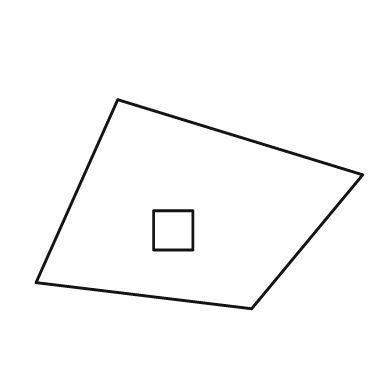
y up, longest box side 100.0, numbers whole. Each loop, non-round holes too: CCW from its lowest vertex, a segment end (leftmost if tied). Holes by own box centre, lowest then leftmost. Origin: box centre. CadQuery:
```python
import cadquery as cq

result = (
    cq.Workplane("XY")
    .moveTo(16.0, -32.0)
    .lineTo(50.0, 9.0)
    .lineTo(-25.0, 32.0)
    .lineTo(-50.0, -24.0)
    .close()
    .moveTo(-14.0, -14.0)
    .lineTo(-2.0, -14.0)
    .lineTo(-2.0, -2.0)
    .lineTo(-14.0, -2.0)
    .close()
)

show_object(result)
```